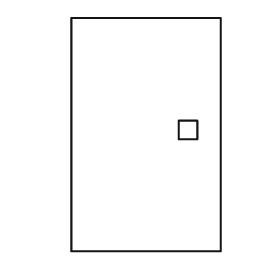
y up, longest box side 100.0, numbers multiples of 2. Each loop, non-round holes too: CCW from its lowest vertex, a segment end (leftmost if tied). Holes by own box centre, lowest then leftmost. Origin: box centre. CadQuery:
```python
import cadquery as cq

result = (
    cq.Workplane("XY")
    .moveTo(-32.0, -50.0)
    .lineTo(32.0, -50.0)
    .lineTo(32.0, 50.0)
    .lineTo(-32.0, 50.0)
    .close()
    .moveTo(14.0, -2.0)
    .lineTo(22.0, -2.0)
    .lineTo(22.0, 6.0)
    .lineTo(14.0, 6.0)
    .close()
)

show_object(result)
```